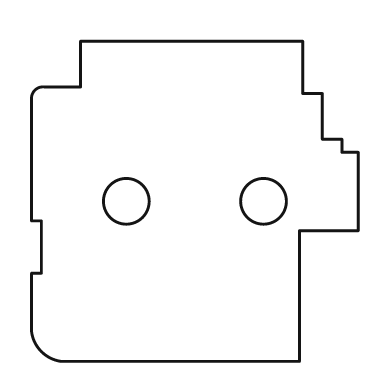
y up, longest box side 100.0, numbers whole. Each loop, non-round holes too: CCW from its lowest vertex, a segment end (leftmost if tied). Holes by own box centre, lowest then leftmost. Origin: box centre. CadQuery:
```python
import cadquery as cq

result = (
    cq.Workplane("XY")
    .moveTo(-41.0, -49.0)
    .lineTo(32.0, -49.0)
    .lineTo(32.0, -9.0)
    .lineTo(50.0, -9.0)
    .lineTo(50.0, 15.0)
    .lineTo(45.0, 15.0)
    .lineTo(45.0, 19.0)
    .lineTo(39.0, 19.0)
    .lineTo(39.0, 33.0)
    .lineTo(33.0, 33.0)
    .lineTo(33.0, 49.0)
    .lineTo(-35.0, 49.0)
    .lineTo(-35.0, 35.0)
    .lineTo(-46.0, 35.0)
    .threePointArc((-49.0, 34.0), (-50.0, 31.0))
    .lineTo(-50.0, -6.0)
    .lineTo(-47.0, -6.0)
    .lineTo(-47.0, -22.0)
    .lineTo(-50.0, -22.0)
    .lineTo(-50.0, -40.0)
    .threePointArc((-47.0, -46.0), (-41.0, -49.0))
    .close()
    .moveTo(-21.0, 0.0)
    .circle(7.0)
    .moveTo(21.0, 0.0)
    .circle(7.0)
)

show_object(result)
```